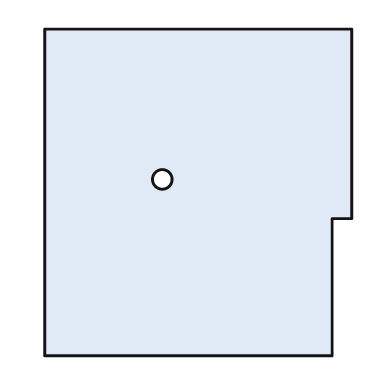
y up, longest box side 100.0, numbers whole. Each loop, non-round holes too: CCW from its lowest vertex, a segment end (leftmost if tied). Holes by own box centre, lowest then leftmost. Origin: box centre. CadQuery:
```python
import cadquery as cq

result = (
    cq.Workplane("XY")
    .moveTo(-47.0, -50.0)
    .lineTo(41.0, -50.0)
    .lineTo(41.0, -8.0)
    .lineTo(47.0, -8.0)
    .lineTo(47.0, 50.0)
    .lineTo(-47.0, 50.0)
    .close()
    .moveTo(-11.0, 4.0)
    .circle(3.0)
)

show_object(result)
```